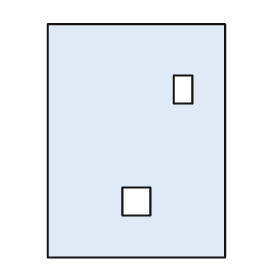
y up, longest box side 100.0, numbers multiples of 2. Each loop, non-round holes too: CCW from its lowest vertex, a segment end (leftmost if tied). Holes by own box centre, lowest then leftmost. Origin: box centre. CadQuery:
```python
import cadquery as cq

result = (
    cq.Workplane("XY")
    .moveTo(-38.0, -50.0)
    .lineTo(38.0, -50.0)
    .lineTo(38.0, 50.0)
    .lineTo(-38.0, 50.0)
    .close()
    .moveTo(-6.0, -32.0)
    .lineTo(6.0, -32.0)
    .lineTo(6.0, -20.0)
    .lineTo(-6.0, -20.0)
    .close()
    .moveTo(16.0, 16.0)
    .lineTo(24.0, 16.0)
    .lineTo(24.0, 28.0)
    .lineTo(16.0, 28.0)
    .close()
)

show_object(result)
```